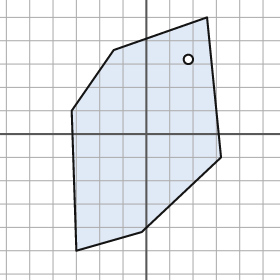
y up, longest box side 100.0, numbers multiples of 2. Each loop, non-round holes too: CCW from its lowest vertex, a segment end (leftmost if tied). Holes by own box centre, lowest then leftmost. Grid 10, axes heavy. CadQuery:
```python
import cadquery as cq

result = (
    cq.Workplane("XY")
    .moveTo(-30.0, -50.0)
    .lineTo(-2.0, -42.0)
    .lineTo(32.0, -10.0)
    .lineTo(26.0, 50.0)
    .lineTo(-14.0, 36.0)
    .lineTo(-32.0, 10.0)
    .close()
    .moveTo(18.0, 32.0)
    .circle(2.0)
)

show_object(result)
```